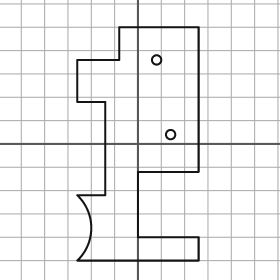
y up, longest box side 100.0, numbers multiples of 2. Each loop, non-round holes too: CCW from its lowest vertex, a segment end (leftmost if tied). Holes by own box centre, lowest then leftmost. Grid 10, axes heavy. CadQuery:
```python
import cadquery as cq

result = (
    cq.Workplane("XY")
    .moveTo(-26.0, -50.0)
    .lineTo(26.0, -50.0)
    .lineTo(26.0, -40.0)
    .lineTo(0.0, -40.0)
    .lineTo(0.0, -12.0)
    .lineTo(26.0, -12.0)
    .lineTo(26.0, 50.0)
    .lineTo(-8.0, 50.0)
    .lineTo(-8.0, 36.0)
    .lineTo(-26.0, 36.0)
    .lineTo(-26.0, 18.0)
    .lineTo(-14.0, 18.0)
    .lineTo(-14.0, -22.0)
    .lineTo(-26.0, -22.0)
    .threePointArc((-20.0, -36.0), (-26.0, -50.0))
    .close()
    .moveTo(14.0, 4.0)
    .circle(2.0)
    .moveTo(8.0, 36.0)
    .circle(2.0)
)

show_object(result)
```